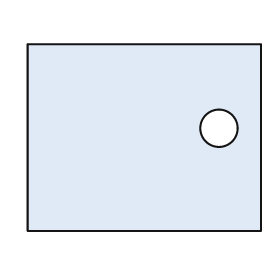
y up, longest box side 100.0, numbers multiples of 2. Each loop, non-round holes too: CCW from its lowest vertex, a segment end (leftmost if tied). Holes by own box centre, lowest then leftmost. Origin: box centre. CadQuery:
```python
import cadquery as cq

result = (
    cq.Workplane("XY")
    .moveTo(-50.0, -40.0)
    .lineTo(50.0, -40.0)
    .lineTo(50.0, 40.0)
    .lineTo(-50.0, 40.0)
    .close()
    .moveTo(32.0, 4.0)
    .circle(8.0)
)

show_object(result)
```